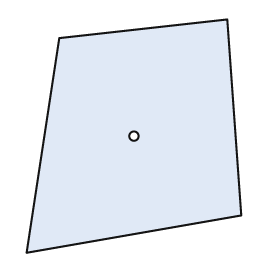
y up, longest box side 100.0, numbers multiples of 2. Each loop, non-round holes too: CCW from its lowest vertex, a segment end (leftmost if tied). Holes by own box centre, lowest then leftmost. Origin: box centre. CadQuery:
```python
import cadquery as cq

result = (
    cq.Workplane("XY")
    .moveTo(-46.0, -50.0)
    .lineTo(46.0, -34.0)
    .lineTo(40.0, 50.0)
    .lineTo(-32.0, 42.0)
    .close()
    .moveTo(0.0, 0.0)
    .circle(2.0)
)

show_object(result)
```